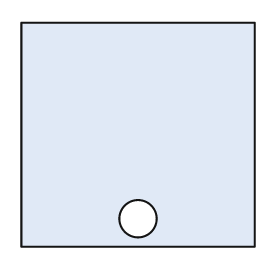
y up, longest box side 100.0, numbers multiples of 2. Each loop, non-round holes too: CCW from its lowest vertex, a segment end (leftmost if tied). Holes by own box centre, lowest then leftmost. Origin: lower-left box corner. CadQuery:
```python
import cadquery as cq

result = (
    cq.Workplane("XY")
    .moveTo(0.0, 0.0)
    .lineTo(100.0, 0.0)
    .lineTo(100.0, 96.0)
    .lineTo(0.0, 96.0)
    .close()
    .moveTo(50.0, 12.0)
    .circle(8.0)
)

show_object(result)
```